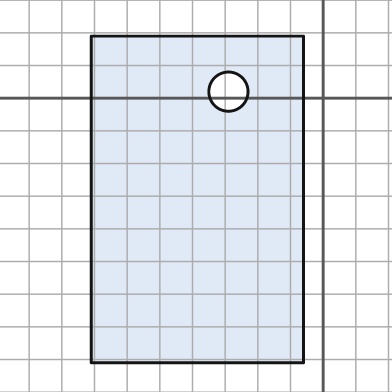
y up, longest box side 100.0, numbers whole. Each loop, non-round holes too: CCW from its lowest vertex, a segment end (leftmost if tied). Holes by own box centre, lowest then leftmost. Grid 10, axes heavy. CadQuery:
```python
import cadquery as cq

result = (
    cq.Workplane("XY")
    .moveTo(-71.0, -81.0)
    .lineTo(-6.0, -81.0)
    .lineTo(-6.0, 19.0)
    .lineTo(-71.0, 19.0)
    .close()
    .moveTo(-29.0, 2.0)
    .circle(6.0)
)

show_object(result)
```